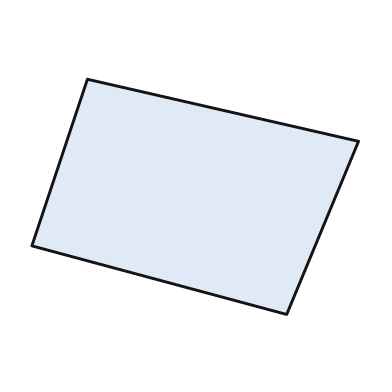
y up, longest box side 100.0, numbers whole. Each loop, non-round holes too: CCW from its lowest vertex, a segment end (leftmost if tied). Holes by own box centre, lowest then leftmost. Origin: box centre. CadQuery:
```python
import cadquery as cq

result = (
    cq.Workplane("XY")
    .moveTo(28.0, -36.0)
    .lineTo(50.0, 17.0)
    .lineTo(-33.0, 36.0)
    .lineTo(-50.0, -15.0)
    .close()
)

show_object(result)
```